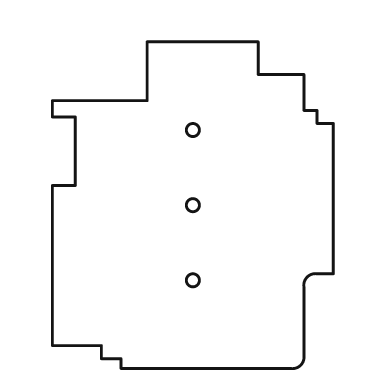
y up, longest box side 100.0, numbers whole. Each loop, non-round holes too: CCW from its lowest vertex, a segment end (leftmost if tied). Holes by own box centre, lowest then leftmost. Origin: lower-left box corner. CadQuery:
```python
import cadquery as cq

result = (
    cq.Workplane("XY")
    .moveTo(21.0, 0.0)
    .lineTo(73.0, 0.0)
    .threePointArc((76.0, 1.0), (77.0, 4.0))
    .lineTo(77.0, 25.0)
    .threePointArc((78.0, 28.0), (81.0, 29.0))
    .lineTo(86.0, 29.0)
    .lineTo(86.0, 75.0)
    .lineTo(81.0, 75.0)
    .lineTo(81.0, 79.0)
    .lineTo(77.0, 79.0)
    .lineTo(77.0, 90.0)
    .lineTo(63.0, 90.0)
    .lineTo(63.0, 100.0)
    .lineTo(29.0, 100.0)
    .lineTo(29.0, 82.0)
    .lineTo(0.0, 82.0)
    .lineTo(0.0, 77.0)
    .lineTo(7.0, 77.0)
    .lineTo(7.0, 56.0)
    .lineTo(0.0, 56.0)
    .lineTo(0.0, 7.0)
    .lineTo(15.0, 7.0)
    .lineTo(15.0, 3.0)
    .lineTo(21.0, 3.0)
    .close()
    .moveTo(43.0, 27.0)
    .circle(2.0)
    .moveTo(43.0, 50.0)
    .circle(2.0)
    .moveTo(43.0, 73.0)
    .circle(2.0)
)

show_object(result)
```